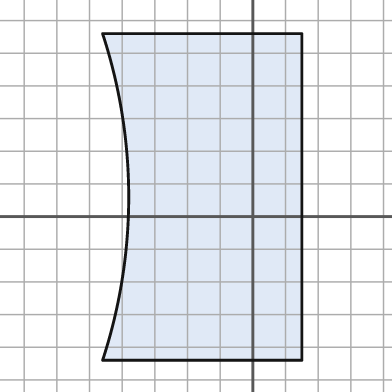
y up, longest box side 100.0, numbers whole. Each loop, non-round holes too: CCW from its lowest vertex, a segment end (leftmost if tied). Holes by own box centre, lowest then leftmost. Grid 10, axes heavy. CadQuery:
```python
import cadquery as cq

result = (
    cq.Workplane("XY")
    .moveTo(-46.0, -44.0)
    .lineTo(15.0, -44.0)
    .lineTo(15.0, 56.0)
    .lineTo(-46.0, 56.0)
    .threePointArc((-38.0, 6.0), (-46.0, -44.0))
    .close()
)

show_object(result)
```